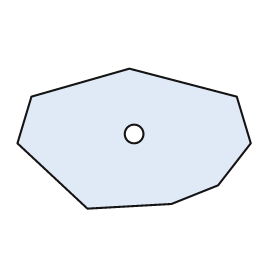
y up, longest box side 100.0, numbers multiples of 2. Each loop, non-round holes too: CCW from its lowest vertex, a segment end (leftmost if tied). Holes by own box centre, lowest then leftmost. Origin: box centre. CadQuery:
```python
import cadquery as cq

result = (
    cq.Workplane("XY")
    .moveTo(-20.0, -30.0)
    .lineTo(16.0, -28.0)
    .lineTo(36.0, -20.0)
    .lineTo(50.0, -2.0)
    .lineTo(44.0, 18.0)
    .lineTo(-2.0, 30.0)
    .lineTo(-44.0, 18.0)
    .lineTo(-50.0, -2.0)
    .close()
    .moveTo(0.0, 2.0)
    .circle(4.0)
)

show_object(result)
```